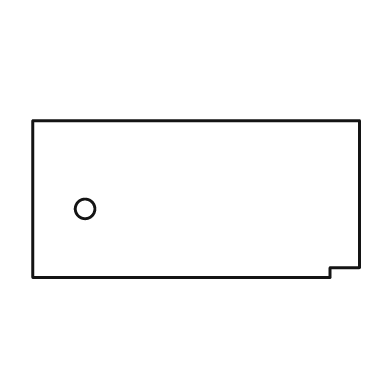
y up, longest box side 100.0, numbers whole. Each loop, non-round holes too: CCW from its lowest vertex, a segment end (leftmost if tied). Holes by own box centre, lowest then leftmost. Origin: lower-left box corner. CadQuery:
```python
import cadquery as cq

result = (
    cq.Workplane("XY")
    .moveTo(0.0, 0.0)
    .lineTo(91.0, 0.0)
    .lineTo(91.0, 3.0)
    .lineTo(100.0, 3.0)
    .lineTo(100.0, 48.0)
    .lineTo(0.0, 48.0)
    .close()
    .moveTo(16.0, 21.0)
    .circle(3.0)
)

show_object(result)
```